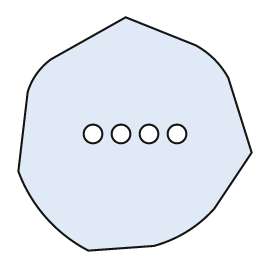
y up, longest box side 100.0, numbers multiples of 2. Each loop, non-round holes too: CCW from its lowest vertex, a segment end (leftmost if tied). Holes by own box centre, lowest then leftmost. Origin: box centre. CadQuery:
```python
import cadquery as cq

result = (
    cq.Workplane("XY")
    .moveTo(-20.0, -50.0)
    .lineTo(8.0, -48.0)
    .threePointArc((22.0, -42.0), (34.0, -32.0))
    .lineTo(50.0, -8.0)
    .lineTo(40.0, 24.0)
    .threePointArc((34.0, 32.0), (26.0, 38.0))
    .lineTo(-4.0, 50.0)
    .lineTo(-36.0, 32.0)
    .threePointArc((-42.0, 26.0), (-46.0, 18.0))
    .lineTo(-50.0, -16.0)
    .threePointArc((-38.0, -36.0), (-20.0, -50.0))
    .close()
    .moveTo(-18.0, 0.0)
    .circle(4.0)
    .moveTo(-6.0, 0.0)
    .circle(4.0)
    .moveTo(6.0, 0.0)
    .circle(4.0)
    .moveTo(18.0, 0.0)
    .circle(4.0)
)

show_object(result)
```